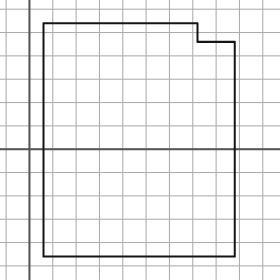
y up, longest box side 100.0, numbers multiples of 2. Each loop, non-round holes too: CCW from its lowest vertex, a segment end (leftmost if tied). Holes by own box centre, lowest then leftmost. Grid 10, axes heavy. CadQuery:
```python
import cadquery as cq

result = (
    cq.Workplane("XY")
    .moveTo(6.0, -46.0)
    .lineTo(88.0, -46.0)
    .lineTo(88.0, 46.0)
    .lineTo(72.0, 46.0)
    .lineTo(72.0, 54.0)
    .lineTo(6.0, 54.0)
    .close()
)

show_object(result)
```